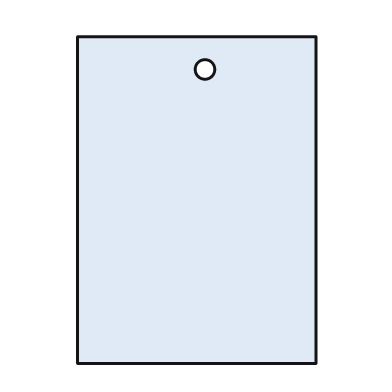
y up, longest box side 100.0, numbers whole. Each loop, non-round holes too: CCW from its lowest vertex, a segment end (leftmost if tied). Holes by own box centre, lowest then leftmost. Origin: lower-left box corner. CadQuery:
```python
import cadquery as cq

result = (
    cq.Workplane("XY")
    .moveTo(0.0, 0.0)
    .lineTo(73.0, 0.0)
    .lineTo(73.0, 100.0)
    .lineTo(0.0, 100.0)
    .close()
    .moveTo(39.0, 90.0)
    .circle(3.0)
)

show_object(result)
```